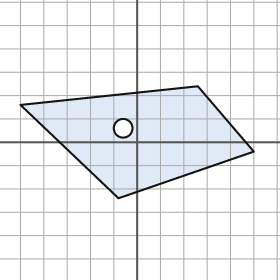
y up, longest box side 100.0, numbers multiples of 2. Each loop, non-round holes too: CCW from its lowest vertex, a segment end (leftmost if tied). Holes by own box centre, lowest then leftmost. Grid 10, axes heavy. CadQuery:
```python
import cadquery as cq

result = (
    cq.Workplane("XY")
    .moveTo(-8.0, -24.0)
    .lineTo(50.0, -4.0)
    .lineTo(26.0, 24.0)
    .lineTo(-50.0, 16.0)
    .close()
    .moveTo(-6.0, 6.0)
    .circle(4.0)
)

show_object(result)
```